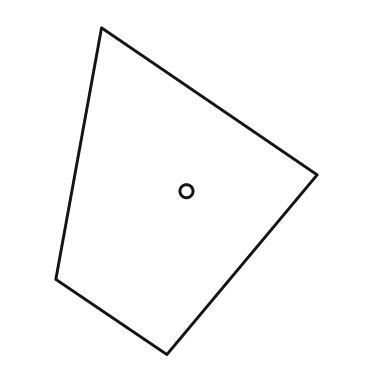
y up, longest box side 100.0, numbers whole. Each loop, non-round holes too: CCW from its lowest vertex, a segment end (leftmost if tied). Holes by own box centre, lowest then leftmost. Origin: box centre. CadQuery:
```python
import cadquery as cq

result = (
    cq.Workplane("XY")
    .moveTo(-6.0, -50.0)
    .lineTo(40.0, 5.0)
    .lineTo(-26.0, 50.0)
    .lineTo(-40.0, -27.0)
    .close()
    .moveTo(0.0, 0.0)
    .circle(2.0)
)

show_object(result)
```